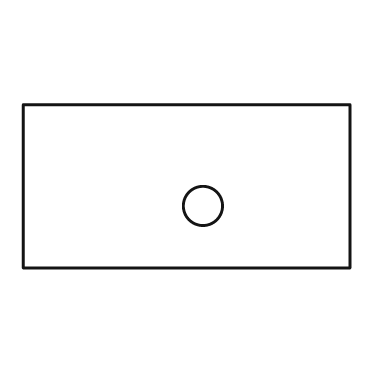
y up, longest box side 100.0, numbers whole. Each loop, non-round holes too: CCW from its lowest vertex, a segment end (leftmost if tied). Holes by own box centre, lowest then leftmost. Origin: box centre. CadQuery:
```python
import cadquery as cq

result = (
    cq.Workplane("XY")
    .moveTo(-50.0, -25.0)
    .lineTo(50.0, -25.0)
    .lineTo(50.0, 25.0)
    .lineTo(-50.0, 25.0)
    .close()
    .moveTo(5.0, -6.0)
    .circle(6.0)
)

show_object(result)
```